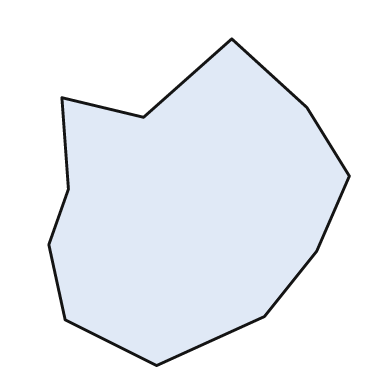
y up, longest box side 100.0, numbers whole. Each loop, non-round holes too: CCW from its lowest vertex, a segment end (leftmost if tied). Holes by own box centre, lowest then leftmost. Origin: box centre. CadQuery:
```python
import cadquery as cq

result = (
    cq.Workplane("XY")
    .moveTo(-13.0, -50.0)
    .lineTo(20.0, -35.0)
    .lineTo(36.0, -15.0)
    .lineTo(46.0, 8.0)
    .lineTo(33.0, 29.0)
    .lineTo(10.0, 50.0)
    .lineTo(-17.0, 26.0)
    .lineTo(-42.0, 32.0)
    .lineTo(-40.0, 4.0)
    .lineTo(-46.0, -13.0)
    .lineTo(-41.0, -36.0)
    .close()
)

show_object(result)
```